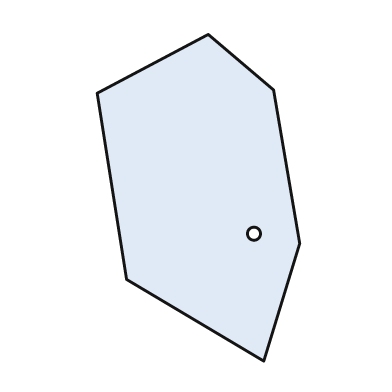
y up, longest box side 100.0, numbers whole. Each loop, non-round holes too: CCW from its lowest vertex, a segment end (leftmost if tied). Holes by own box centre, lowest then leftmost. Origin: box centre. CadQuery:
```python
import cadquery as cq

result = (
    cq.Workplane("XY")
    .moveTo(20.0, -50.0)
    .lineTo(31.0, -14.0)
    .lineTo(23.0, 33.0)
    .lineTo(3.0, 50.0)
    .lineTo(-31.0, 32.0)
    .lineTo(-22.0, -25.0)
    .close()
    .moveTo(17.0, -11.0)
    .circle(2.0)
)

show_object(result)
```